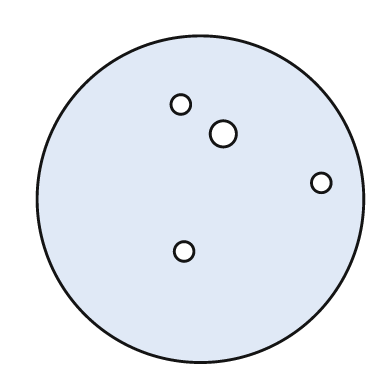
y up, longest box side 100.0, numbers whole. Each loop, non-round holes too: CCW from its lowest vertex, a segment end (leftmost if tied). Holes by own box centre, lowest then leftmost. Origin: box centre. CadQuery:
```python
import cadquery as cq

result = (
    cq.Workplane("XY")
    .moveTo(0.0, 0.0)
    .circle(50.0)
    .moveTo(-5.0, -16.0)
    .circle(3.0)
    .moveTo(37.0, 5.0)
    .circle(3.0)
    .moveTo(7.0, 20.0)
    .circle(4.0)
    .moveTo(-6.0, 29.0)
    .circle(3.0)
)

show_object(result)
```